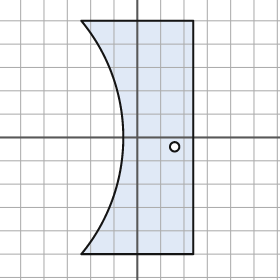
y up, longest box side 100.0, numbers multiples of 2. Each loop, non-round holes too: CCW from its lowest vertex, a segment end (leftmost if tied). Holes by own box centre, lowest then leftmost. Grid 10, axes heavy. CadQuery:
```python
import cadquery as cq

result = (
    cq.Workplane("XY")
    .moveTo(-24.0, -50.0)
    .lineTo(24.0, -50.0)
    .lineTo(24.0, 50.0)
    .lineTo(-24.0, 50.0)
    .threePointArc((-6.0, 0.0), (-24.0, -50.0))
    .close()
    .moveTo(16.0, -4.0)
    .circle(2.0)
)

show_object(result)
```